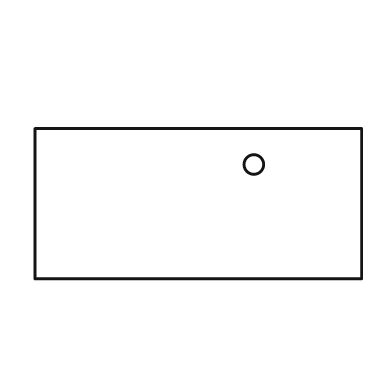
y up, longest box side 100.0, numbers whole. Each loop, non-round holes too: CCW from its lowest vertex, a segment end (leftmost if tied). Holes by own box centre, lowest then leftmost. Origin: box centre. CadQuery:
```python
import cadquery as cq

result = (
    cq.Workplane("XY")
    .moveTo(-50.0, -23.0)
    .lineTo(50.0, -23.0)
    .lineTo(50.0, 23.0)
    .lineTo(-50.0, 23.0)
    .close()
    .moveTo(17.0, 12.0)
    .circle(3.0)
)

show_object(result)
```